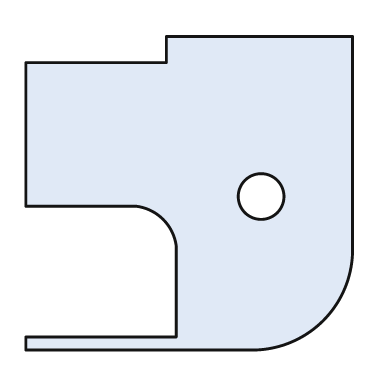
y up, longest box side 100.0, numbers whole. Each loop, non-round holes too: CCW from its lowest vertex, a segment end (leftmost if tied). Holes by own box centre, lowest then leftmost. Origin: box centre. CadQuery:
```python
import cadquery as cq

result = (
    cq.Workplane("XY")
    .moveTo(-50.0, -48.0)
    .lineTo(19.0, -48.0)
    .threePointArc((41.0, -39.0), (50.0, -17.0))
    .lineTo(50.0, 48.0)
    .lineTo(-7.0, 48.0)
    .lineTo(-7.0, 40.0)
    .lineTo(-50.0, 40.0)
    .lineTo(-50.0, -4.0)
    .lineTo(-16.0, -4.0)
    .threePointArc((-8.0, -8.0), (-4.0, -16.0))
    .lineTo(-4.0, -44.0)
    .lineTo(-50.0, -44.0)
    .close()
    .moveTo(22.0, -1.0)
    .circle(7.0)
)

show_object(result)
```